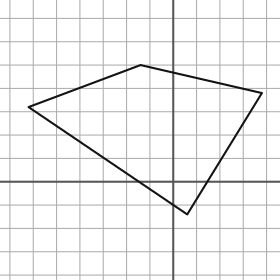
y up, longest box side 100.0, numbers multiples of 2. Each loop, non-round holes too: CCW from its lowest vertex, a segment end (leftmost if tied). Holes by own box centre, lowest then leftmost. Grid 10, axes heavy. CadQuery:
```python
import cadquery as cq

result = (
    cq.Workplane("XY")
    .moveTo(6.0, -14.0)
    .lineTo(38.0, 38.0)
    .lineTo(-14.0, 50.0)
    .lineTo(-62.0, 32.0)
    .close()
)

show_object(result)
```